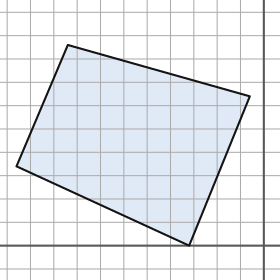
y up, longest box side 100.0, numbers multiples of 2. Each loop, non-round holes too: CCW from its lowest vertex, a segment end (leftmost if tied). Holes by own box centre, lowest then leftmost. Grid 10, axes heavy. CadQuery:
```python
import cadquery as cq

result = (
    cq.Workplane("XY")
    .moveTo(-32.0, 0.0)
    .lineTo(-6.0, 64.0)
    .lineTo(-84.0, 86.0)
    .lineTo(-106.0, 34.0)
    .close()
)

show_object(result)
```